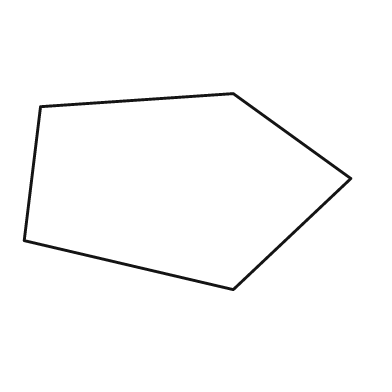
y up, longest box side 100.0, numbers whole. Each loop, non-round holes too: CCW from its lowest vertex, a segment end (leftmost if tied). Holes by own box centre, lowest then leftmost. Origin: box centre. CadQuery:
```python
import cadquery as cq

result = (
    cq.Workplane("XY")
    .moveTo(14.0, -30.0)
    .lineTo(50.0, 4.0)
    .lineTo(14.0, 30.0)
    .lineTo(-45.0, 26.0)
    .lineTo(-50.0, -15.0)
    .close()
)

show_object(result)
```